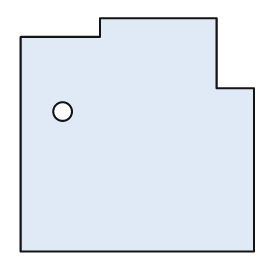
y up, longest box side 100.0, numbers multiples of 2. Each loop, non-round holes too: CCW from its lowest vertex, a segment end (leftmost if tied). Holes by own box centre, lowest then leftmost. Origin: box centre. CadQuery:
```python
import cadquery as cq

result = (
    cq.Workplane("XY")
    .moveTo(-50.0, -50.0)
    .lineTo(50.0, -50.0)
    .lineTo(50.0, 20.0)
    .lineTo(34.0, 20.0)
    .lineTo(34.0, 50.0)
    .lineTo(-16.0, 50.0)
    .lineTo(-16.0, 42.0)
    .lineTo(-50.0, 42.0)
    .close()
    .moveTo(-32.0, 10.0)
    .circle(4.0)
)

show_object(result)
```